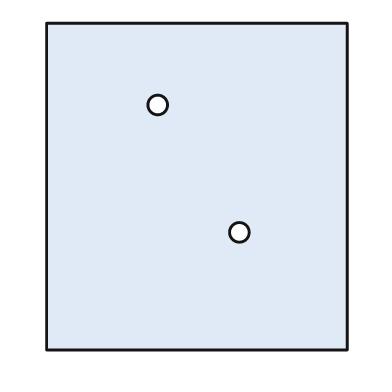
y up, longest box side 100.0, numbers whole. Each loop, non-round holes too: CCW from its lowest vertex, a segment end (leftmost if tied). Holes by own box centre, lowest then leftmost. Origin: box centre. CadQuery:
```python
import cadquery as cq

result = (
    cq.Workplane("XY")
    .moveTo(-46.0, -50.0)
    .lineTo(46.0, -50.0)
    .lineTo(46.0, 50.0)
    .lineTo(-46.0, 50.0)
    .close()
    .moveTo(13.0, -14.0)
    .circle(3.0)
    .moveTo(-12.0, 25.0)
    .circle(3.0)
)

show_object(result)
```